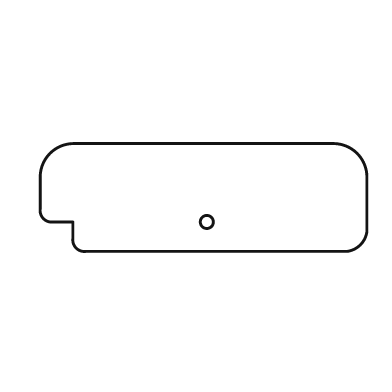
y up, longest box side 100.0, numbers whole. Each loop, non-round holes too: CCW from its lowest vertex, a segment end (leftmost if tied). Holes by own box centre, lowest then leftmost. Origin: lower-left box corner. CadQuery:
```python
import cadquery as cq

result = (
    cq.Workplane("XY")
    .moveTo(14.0, 0.0)
    .lineTo(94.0, 0.0)
    .threePointArc((98.0, 2.0), (100.0, 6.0))
    .lineTo(100.0, 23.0)
    .threePointArc((97.0, 30.0), (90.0, 33.0))
    .lineTo(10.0, 33.0)
    .threePointArc((3.0, 30.0), (0.0, 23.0))
    .lineTo(0.0, 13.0)
    .threePointArc((1.0, 10.0), (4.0, 9.0))
    .lineTo(10.0, 9.0)
    .lineTo(10.0, 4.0)
    .threePointArc((11.0, 1.0), (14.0, 0.0))
    .close()
    .moveTo(51.0, 9.0)
    .circle(2.0)
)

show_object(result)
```